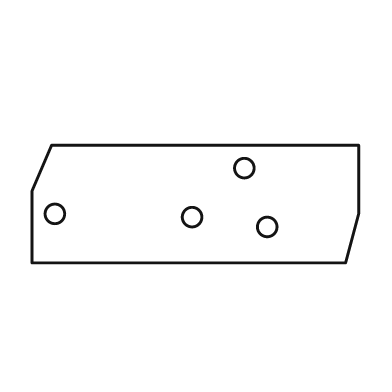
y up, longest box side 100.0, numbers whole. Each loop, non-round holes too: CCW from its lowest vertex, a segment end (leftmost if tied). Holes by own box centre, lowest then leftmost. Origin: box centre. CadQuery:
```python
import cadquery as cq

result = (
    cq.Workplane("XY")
    .moveTo(-50.0, -18.0)
    .lineTo(46.0, -18.0)
    .lineTo(50.0, -3.0)
    .lineTo(50.0, 18.0)
    .lineTo(-44.0, 18.0)
    .lineTo(-50.0, 4.0)
    .close()
    .moveTo(22.0, -7.0)
    .circle(3.0)
    .moveTo(-1.0, -4.0)
    .circle(3.0)
    .moveTo(-43.0, -3.0)
    .circle(3.0)
    .moveTo(15.0, 11.0)
    .circle(3.0)
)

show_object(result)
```